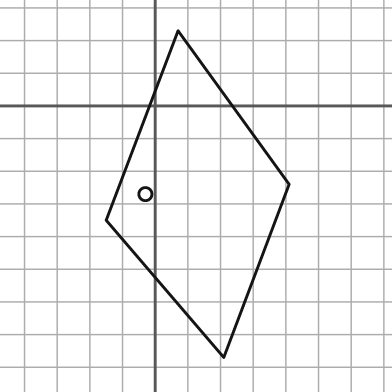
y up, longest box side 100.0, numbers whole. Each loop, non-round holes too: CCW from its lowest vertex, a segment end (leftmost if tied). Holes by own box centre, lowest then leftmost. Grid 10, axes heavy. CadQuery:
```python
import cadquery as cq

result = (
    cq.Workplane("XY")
    .moveTo(21.0, -77.0)
    .lineTo(41.0, -24.0)
    .lineTo(7.0, 23.0)
    .lineTo(-15.0, -35.0)
    .close()
    .moveTo(-3.0, -27.0)
    .circle(2.0)
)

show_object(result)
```